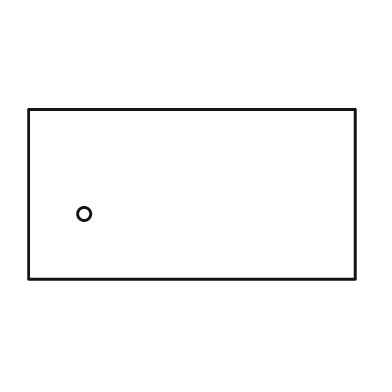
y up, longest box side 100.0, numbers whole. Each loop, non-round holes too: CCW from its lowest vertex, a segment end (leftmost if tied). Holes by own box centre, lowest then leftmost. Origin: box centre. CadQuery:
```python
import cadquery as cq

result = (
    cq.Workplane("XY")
    .moveTo(-50.0, -26.0)
    .lineTo(50.0, -26.0)
    .lineTo(50.0, 26.0)
    .lineTo(-50.0, 26.0)
    .close()
    .moveTo(-33.0, -6.0)
    .circle(2.0)
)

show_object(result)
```